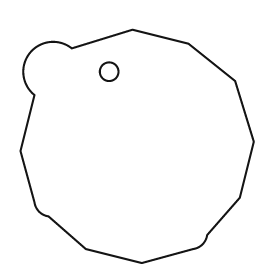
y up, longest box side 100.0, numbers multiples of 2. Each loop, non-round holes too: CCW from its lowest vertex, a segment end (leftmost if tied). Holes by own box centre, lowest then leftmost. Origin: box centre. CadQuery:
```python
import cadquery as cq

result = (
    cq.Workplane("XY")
    .moveTo(2.0, -50.0)
    .lineTo(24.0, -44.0)
    .threePointArc((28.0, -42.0), (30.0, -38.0))
    .lineTo(44.0, -22.0)
    .lineTo(50.0, 2.0)
    .lineTo(42.0, 28.0)
    .lineTo(22.0, 44.0)
    .lineTo(-2.0, 50.0)
    .lineTo(-28.0, 42.0)
    .threePointArc((-46.0, 40.0), (-44.0, 22.0))
    .lineTo(-50.0, -2.0)
    .lineTo(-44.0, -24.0)
    .threePointArc((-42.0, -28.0), (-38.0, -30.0))
    .lineTo(-22.0, -44.0)
    .close()
    .moveTo(-12.0, 32.0)
    .circle(4.0)
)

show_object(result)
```